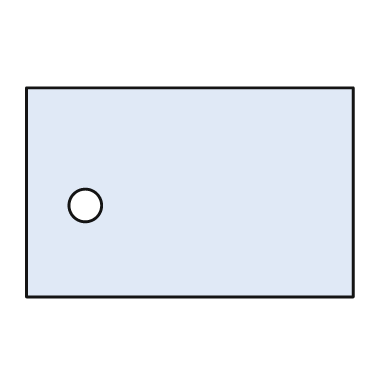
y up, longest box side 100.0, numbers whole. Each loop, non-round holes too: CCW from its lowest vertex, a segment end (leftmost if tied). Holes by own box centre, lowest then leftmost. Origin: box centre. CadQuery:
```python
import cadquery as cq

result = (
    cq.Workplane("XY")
    .moveTo(-50.0, -32.0)
    .lineTo(50.0, -32.0)
    .lineTo(50.0, 32.0)
    .lineTo(-50.0, 32.0)
    .close()
    .moveTo(-32.0, -4.0)
    .circle(5.0)
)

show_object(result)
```